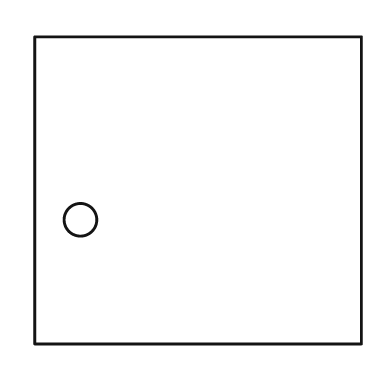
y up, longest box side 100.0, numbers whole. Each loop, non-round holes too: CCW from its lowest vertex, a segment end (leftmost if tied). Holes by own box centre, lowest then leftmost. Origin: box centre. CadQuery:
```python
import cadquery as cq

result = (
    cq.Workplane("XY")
    .moveTo(-50.0, -47.0)
    .lineTo(50.0, -47.0)
    .lineTo(50.0, 47.0)
    .lineTo(-50.0, 47.0)
    .close()
    .moveTo(-36.0, -9.0)
    .circle(5.0)
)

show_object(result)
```